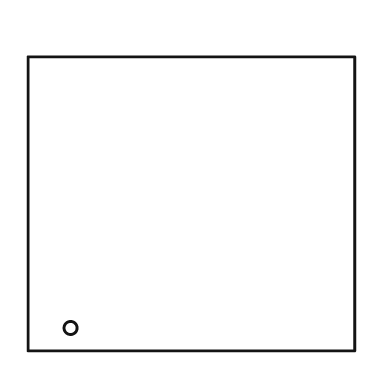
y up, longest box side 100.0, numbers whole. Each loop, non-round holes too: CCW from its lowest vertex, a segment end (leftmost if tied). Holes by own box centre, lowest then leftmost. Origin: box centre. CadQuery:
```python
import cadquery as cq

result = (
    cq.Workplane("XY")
    .moveTo(-50.0, -45.0)
    .lineTo(50.0, -45.0)
    .lineTo(50.0, 45.0)
    .lineTo(-50.0, 45.0)
    .close()
    .moveTo(-37.0, -38.0)
    .circle(2.0)
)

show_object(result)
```